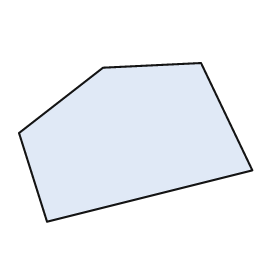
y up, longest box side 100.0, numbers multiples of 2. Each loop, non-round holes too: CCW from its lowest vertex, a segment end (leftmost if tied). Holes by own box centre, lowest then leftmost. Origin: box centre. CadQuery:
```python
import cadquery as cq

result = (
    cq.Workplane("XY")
    .moveTo(-38.0, -34.0)
    .lineTo(50.0, -12.0)
    .lineTo(28.0, 34.0)
    .lineTo(-14.0, 32.0)
    .lineTo(-50.0, 4.0)
    .close()
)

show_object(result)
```